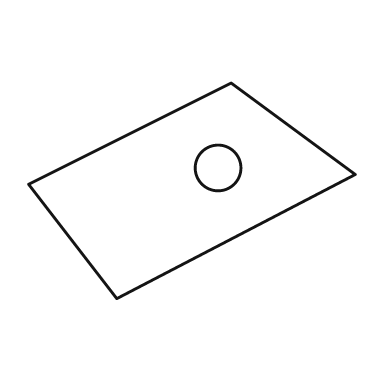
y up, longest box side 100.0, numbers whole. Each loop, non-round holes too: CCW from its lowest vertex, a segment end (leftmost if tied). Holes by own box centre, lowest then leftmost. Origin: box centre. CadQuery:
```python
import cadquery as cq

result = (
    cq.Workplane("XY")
    .moveTo(-23.0, -33.0)
    .lineTo(50.0, 5.0)
    .lineTo(12.0, 33.0)
    .lineTo(-50.0, 2.0)
    .close()
    .moveTo(8.0, 7.0)
    .circle(7.0)
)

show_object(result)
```